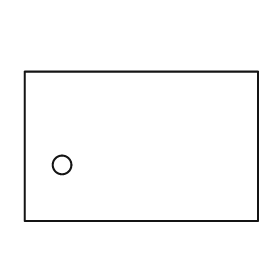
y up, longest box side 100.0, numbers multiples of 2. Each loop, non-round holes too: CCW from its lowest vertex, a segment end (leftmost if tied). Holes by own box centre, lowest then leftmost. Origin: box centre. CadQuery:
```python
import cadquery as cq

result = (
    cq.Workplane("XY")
    .moveTo(-50.0, -32.0)
    .lineTo(50.0, -32.0)
    .lineTo(50.0, 32.0)
    .lineTo(-50.0, 32.0)
    .close()
    .moveTo(-34.0, -8.0)
    .circle(4.0)
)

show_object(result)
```